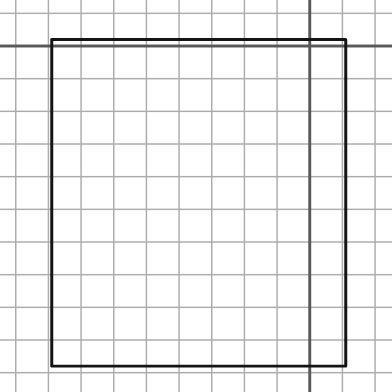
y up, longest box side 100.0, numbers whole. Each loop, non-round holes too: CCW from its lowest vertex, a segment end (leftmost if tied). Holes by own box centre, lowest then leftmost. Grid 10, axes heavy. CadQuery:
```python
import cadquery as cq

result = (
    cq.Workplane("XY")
    .moveTo(-79.0, -98.0)
    .lineTo(11.0, -98.0)
    .lineTo(11.0, 2.0)
    .lineTo(-79.0, 2.0)
    .close()
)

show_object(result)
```